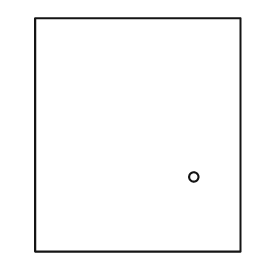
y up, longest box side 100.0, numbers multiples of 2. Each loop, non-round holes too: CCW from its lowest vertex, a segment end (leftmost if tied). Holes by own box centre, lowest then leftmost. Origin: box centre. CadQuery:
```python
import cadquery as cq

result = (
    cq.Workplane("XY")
    .moveTo(-44.0, -50.0)
    .lineTo(44.0, -50.0)
    .lineTo(44.0, 50.0)
    .lineTo(-44.0, 50.0)
    .close()
    .moveTo(24.0, -18.0)
    .circle(2.0)
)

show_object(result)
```